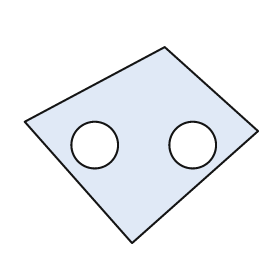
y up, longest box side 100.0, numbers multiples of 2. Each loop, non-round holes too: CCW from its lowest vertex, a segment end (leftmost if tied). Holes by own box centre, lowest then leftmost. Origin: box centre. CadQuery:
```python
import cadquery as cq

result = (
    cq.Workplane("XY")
    .moveTo(-4.0, -42.0)
    .lineTo(50.0, 6.0)
    .lineTo(10.0, 42.0)
    .lineTo(-50.0, 10.0)
    .close()
    .moveTo(-20.0, 0.0)
    .circle(10.0)
    .moveTo(22.0, 0.0)
    .circle(10.0)
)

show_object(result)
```